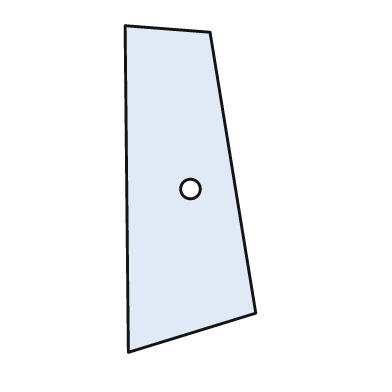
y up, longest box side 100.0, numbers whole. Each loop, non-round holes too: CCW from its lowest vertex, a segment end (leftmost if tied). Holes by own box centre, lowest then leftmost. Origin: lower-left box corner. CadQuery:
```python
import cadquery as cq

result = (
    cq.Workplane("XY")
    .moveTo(1.0, 0.0)
    .lineTo(40.0, 12.0)
    .lineTo(26.0, 98.0)
    .lineTo(0.0, 100.0)
    .close()
    .moveTo(20.0, 50.0)
    .circle(3.0)
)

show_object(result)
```